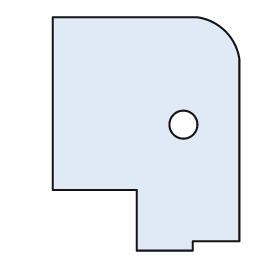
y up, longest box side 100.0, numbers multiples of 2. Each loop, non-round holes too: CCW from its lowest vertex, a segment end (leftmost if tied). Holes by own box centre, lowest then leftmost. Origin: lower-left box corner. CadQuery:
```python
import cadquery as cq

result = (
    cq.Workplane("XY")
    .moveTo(36.0, 0.0)
    .lineTo(60.0, 0.0)
    .lineTo(60.0, 4.0)
    .lineTo(80.0, 4.0)
    .lineTo(80.0, 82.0)
    .threePointArc((74.0, 94.0), (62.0, 100.0))
    .lineTo(0.0, 100.0)
    .lineTo(0.0, 26.0)
    .lineTo(36.0, 26.0)
    .close()
    .moveTo(56.0, 54.0)
    .circle(6.0)
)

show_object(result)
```